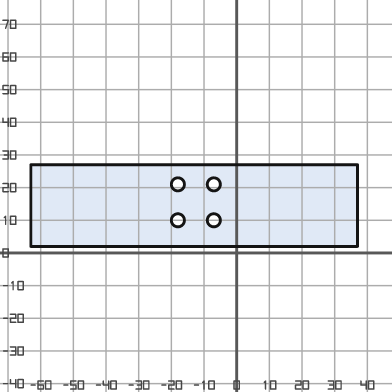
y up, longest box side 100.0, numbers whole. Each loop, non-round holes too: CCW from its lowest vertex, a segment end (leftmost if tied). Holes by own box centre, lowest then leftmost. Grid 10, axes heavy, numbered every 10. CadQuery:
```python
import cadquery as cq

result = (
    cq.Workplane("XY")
    .moveTo(-63.0, 2.0)
    .lineTo(37.0, 2.0)
    .lineTo(37.0, 27.0)
    .lineTo(-63.0, 27.0)
    .close()
    .moveTo(-18.0, 10.0)
    .circle(2.0)
    .moveTo(-7.0, 10.0)
    .circle(2.0)
    .moveTo(-18.0, 21.0)
    .circle(2.0)
    .moveTo(-7.0, 21.0)
    .circle(2.0)
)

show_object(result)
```